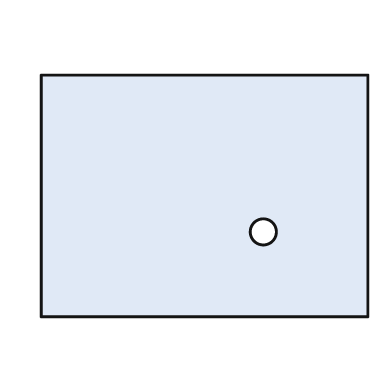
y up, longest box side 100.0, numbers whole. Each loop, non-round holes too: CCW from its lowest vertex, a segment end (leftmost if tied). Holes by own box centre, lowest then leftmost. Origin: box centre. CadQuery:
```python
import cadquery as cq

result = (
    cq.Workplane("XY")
    .moveTo(-50.0, -37.0)
    .lineTo(50.0, -37.0)
    .lineTo(50.0, 37.0)
    .lineTo(-50.0, 37.0)
    .close()
    .moveTo(18.0, -11.0)
    .circle(4.0)
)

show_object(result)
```